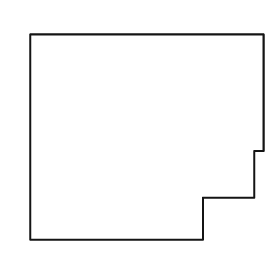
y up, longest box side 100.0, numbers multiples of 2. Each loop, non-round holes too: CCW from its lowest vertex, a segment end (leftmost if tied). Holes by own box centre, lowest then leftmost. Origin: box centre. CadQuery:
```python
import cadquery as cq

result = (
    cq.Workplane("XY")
    .moveTo(-50.0, -44.0)
    .lineTo(24.0, -44.0)
    .lineTo(24.0, -26.0)
    .lineTo(46.0, -26.0)
    .lineTo(46.0, -6.0)
    .lineTo(50.0, -6.0)
    .lineTo(50.0, 44.0)
    .lineTo(-50.0, 44.0)
    .close()
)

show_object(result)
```